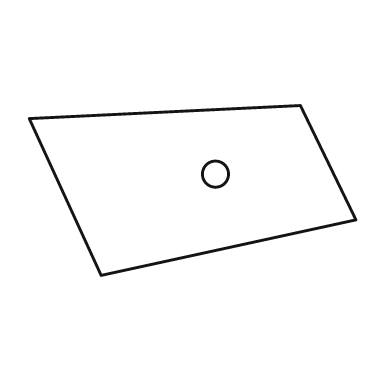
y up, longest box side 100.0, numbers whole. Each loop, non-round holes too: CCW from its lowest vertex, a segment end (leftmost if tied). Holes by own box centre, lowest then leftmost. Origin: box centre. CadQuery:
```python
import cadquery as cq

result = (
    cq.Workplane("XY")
    .moveTo(-28.0, -26.0)
    .lineTo(50.0, -9.0)
    .lineTo(33.0, 26.0)
    .lineTo(-50.0, 22.0)
    .close()
    .moveTo(7.0, 5.0)
    .circle(4.0)
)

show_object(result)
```